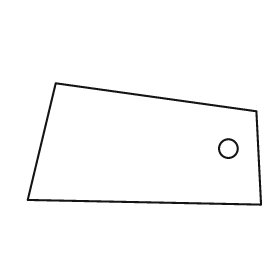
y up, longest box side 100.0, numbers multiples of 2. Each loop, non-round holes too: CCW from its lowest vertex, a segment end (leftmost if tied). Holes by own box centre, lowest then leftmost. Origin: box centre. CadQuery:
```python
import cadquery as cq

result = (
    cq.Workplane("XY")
    .moveTo(50.0, -26.0)
    .lineTo(48.0, 14.0)
    .lineTo(-38.0, 26.0)
    .lineTo(-50.0, -24.0)
    .close()
    .moveTo(36.0, -2.0)
    .circle(4.0)
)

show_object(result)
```